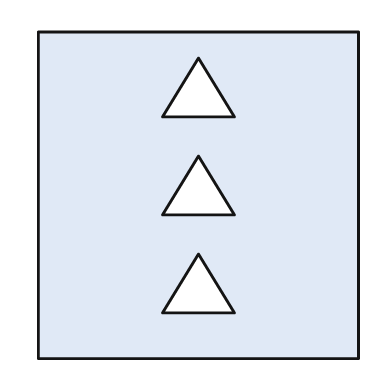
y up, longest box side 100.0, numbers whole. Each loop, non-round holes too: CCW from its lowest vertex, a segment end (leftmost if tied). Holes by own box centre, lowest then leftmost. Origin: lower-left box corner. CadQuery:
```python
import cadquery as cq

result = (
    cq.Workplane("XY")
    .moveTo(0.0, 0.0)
    .lineTo(98.0, 0.0)
    .lineTo(98.0, 100.0)
    .lineTo(0.0, 100.0)
    .close()
    .moveTo(38.0, 14.0)
    .lineTo(60.0, 14.0)
    .lineTo(49.0, 32.0)
    .close()
    .moveTo(38.0, 44.0)
    .lineTo(60.0, 44.0)
    .lineTo(49.0, 62.0)
    .close()
    .moveTo(38.0, 74.0)
    .lineTo(60.0, 74.0)
    .lineTo(49.0, 92.0)
    .close()
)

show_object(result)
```